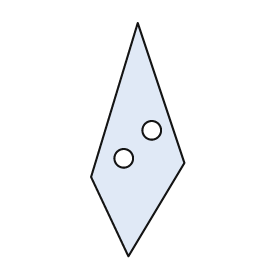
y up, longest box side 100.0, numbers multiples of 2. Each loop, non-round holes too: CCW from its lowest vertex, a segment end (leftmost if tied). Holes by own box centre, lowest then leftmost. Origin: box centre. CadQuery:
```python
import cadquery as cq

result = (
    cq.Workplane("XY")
    .moveTo(-4.0, -50.0)
    .lineTo(20.0, -10.0)
    .lineTo(0.0, 50.0)
    .lineTo(-20.0, -16.0)
    .close()
    .moveTo(-6.0, -8.0)
    .circle(4.0)
    .moveTo(6.0, 4.0)
    .circle(4.0)
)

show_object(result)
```